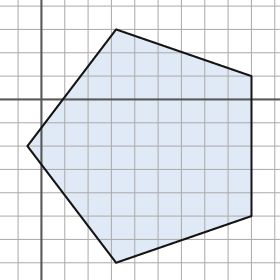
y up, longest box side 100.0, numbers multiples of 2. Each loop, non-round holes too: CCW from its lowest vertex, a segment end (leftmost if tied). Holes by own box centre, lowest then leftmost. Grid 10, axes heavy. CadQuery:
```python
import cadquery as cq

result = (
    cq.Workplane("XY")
    .moveTo(32.0, -70.0)
    .lineTo(90.0, -50.0)
    .lineTo(90.0, 10.0)
    .lineTo(32.0, 30.0)
    .lineTo(-6.0, -20.0)
    .close()
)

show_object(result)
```